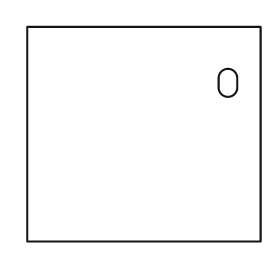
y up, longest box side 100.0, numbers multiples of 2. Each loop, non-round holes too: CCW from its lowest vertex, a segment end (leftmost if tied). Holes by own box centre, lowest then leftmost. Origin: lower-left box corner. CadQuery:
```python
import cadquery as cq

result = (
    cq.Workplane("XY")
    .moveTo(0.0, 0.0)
    .lineTo(100.0, 0.0)
    .lineTo(100.0, 92.0)
    .lineTo(0.0, 92.0)
    .close()
    .moveTo(82.0, 66.0)
    .threePointArc((86.0, 62.0), (90.0, 66.0))
    .lineTo(90.0, 70.0)
    .threePointArc((86.0, 74.0), (82.0, 70.0))
    .close()
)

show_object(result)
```